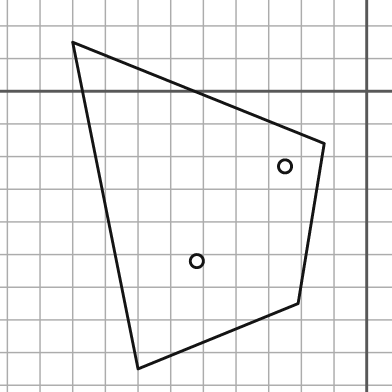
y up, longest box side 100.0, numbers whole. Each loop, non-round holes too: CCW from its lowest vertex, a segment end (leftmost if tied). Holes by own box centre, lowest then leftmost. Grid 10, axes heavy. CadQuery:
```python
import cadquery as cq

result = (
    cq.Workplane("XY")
    .moveTo(-70.0, -85.0)
    .lineTo(-21.0, -65.0)
    .lineTo(-13.0, -16.0)
    .lineTo(-90.0, 15.0)
    .close()
    .moveTo(-52.0, -52.0)
    .circle(2.0)
    .moveTo(-25.0, -23.0)
    .circle(2.0)
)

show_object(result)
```